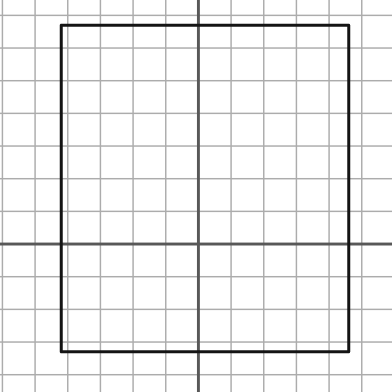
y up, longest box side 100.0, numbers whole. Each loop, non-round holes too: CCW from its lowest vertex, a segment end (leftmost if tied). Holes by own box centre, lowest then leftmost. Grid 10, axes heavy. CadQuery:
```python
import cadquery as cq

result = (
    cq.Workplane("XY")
    .moveTo(-42.0, -33.0)
    .lineTo(46.0, -33.0)
    .lineTo(46.0, 67.0)
    .lineTo(-42.0, 67.0)
    .close()
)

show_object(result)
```